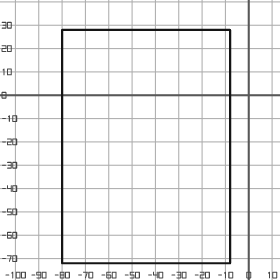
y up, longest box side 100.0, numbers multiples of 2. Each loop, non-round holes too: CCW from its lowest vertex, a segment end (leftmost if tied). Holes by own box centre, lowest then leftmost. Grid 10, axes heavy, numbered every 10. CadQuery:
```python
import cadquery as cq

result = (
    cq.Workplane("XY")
    .moveTo(-80.0, -72.0)
    .lineTo(-8.0, -72.0)
    .lineTo(-8.0, 28.0)
    .lineTo(-80.0, 28.0)
    .close()
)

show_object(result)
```